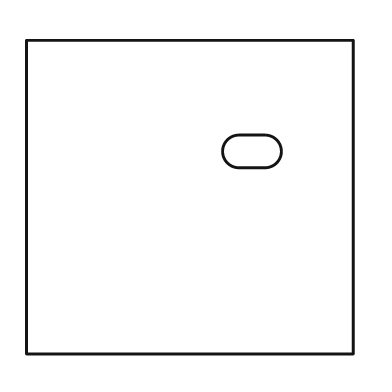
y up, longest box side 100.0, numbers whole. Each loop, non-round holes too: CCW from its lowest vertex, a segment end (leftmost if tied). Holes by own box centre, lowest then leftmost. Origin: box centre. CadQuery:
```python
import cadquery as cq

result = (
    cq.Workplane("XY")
    .moveTo(-50.0, -48.0)
    .lineTo(50.0, -48.0)
    .lineTo(50.0, 48.0)
    .lineTo(-50.0, 48.0)
    .close()
    .moveTo(15.0, 9.0)
    .lineTo(23.0, 9.0)
    .threePointArc((28.0, 14.0), (23.0, 19.0))
    .lineTo(15.0, 19.0)
    .threePointArc((10.0, 14.0), (15.0, 9.0))
    .close()
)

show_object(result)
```